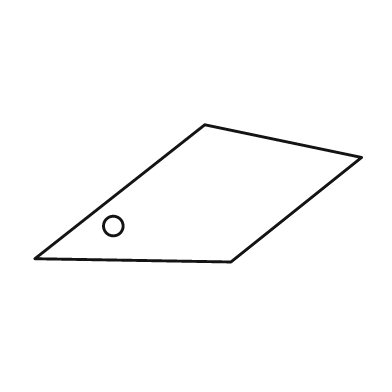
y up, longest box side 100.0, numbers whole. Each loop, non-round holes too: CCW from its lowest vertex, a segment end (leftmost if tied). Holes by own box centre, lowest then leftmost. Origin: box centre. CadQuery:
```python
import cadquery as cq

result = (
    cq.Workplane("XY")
    .moveTo(10.0, -21.0)
    .lineTo(50.0, 11.0)
    .lineTo(2.0, 21.0)
    .lineTo(-50.0, -20.0)
    .close()
    .moveTo(-26.0, -10.0)
    .circle(3.0)
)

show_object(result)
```